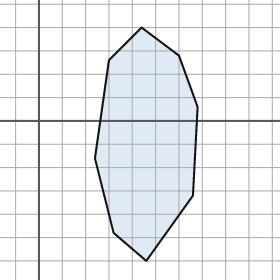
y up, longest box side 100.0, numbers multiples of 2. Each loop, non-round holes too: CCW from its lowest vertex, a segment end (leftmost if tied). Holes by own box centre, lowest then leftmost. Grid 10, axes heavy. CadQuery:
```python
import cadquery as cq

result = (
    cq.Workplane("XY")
    .moveTo(46.0, -60.0)
    .lineTo(66.0, -32.0)
    .lineTo(68.0, 6.0)
    .lineTo(60.0, 28.0)
    .lineTo(44.0, 40.0)
    .lineTo(30.0, 26.0)
    .lineTo(24.0, -16.0)
    .lineTo(32.0, -48.0)
    .close()
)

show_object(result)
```